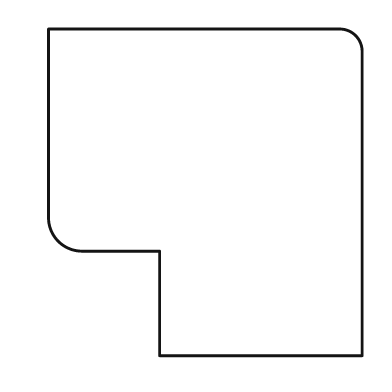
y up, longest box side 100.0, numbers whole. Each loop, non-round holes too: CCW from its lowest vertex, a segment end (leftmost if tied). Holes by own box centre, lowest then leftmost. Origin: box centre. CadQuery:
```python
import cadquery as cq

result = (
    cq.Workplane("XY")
    .moveTo(-14.0, -50.0)
    .lineTo(48.0, -50.0)
    .lineTo(48.0, 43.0)
    .threePointArc((46.0, 48.0), (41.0, 50.0))
    .lineTo(-48.0, 50.0)
    .lineTo(-48.0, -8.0)
    .threePointArc((-45.0, -15.0), (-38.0, -18.0))
    .lineTo(-14.0, -18.0)
    .close()
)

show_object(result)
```